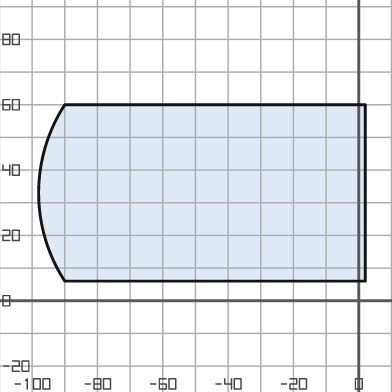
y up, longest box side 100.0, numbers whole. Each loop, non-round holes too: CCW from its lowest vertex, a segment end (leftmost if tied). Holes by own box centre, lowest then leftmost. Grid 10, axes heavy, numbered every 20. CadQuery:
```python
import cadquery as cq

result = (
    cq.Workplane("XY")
    .moveTo(-90.0, 6.0)
    .lineTo(2.0, 6.0)
    .lineTo(2.0, 60.0)
    .lineTo(-90.0, 60.0)
    .threePointArc((-98.0, 33.0), (-90.0, 6.0))
    .close()
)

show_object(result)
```